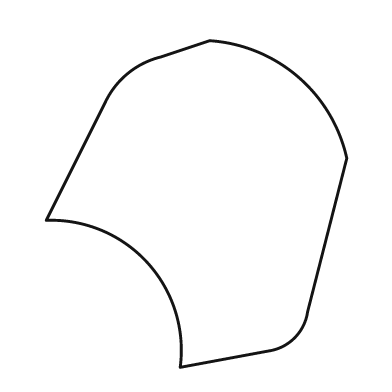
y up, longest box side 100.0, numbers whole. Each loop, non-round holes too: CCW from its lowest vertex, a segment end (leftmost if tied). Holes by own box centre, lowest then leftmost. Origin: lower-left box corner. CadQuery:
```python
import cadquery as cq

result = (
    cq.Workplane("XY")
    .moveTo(41.0, 0.0)
    .lineTo(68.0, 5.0)
    .threePointArc((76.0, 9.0), (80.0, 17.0))
    .lineTo(92.0, 64.0)
    .threePointArc((77.0, 89.0), (50.0, 100.0))
    .lineTo(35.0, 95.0)
    .threePointArc((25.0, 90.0), (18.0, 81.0))
    .lineTo(0.0, 45.0)
    .threePointArc((31.0, 32.0), (41.0, 0.0))
    .close()
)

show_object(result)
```